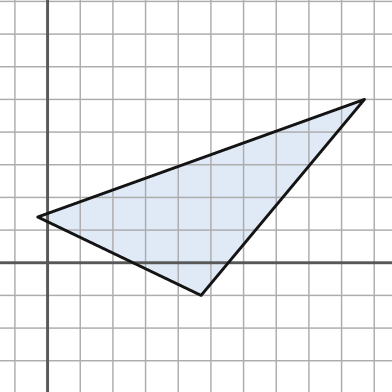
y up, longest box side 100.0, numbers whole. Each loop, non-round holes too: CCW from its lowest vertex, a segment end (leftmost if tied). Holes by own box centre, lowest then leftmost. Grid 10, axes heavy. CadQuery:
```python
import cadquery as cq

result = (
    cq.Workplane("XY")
    .moveTo(47.0, -10.0)
    .lineTo(97.0, 50.0)
    .lineTo(-3.0, 14.0)
    .close()
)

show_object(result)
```